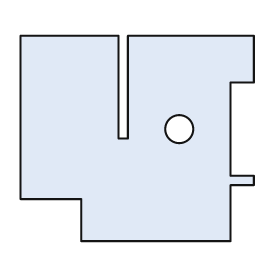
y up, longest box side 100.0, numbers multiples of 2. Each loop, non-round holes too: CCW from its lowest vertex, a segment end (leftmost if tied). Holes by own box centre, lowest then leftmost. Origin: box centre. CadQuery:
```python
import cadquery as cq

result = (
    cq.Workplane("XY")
    .moveTo(-24.0, -44.0)
    .lineTo(40.0, -44.0)
    .lineTo(40.0, -20.0)
    .lineTo(50.0, -20.0)
    .lineTo(50.0, -16.0)
    .lineTo(40.0, -16.0)
    .lineTo(40.0, 24.0)
    .lineTo(50.0, 24.0)
    .lineTo(50.0, 44.0)
    .lineTo(-4.0, 44.0)
    .lineTo(-4.0, 0.0)
    .lineTo(-8.0, 0.0)
    .lineTo(-8.0, 44.0)
    .lineTo(-50.0, 44.0)
    .lineTo(-50.0, -26.0)
    .lineTo(-24.0, -26.0)
    .close()
    .moveTo(18.0, 4.0)
    .circle(6.0)
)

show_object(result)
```